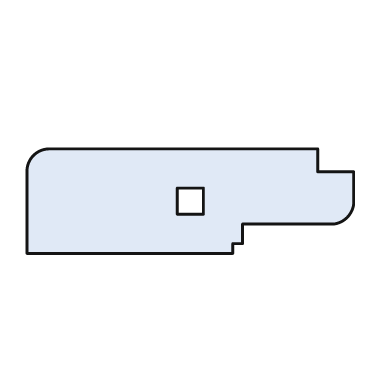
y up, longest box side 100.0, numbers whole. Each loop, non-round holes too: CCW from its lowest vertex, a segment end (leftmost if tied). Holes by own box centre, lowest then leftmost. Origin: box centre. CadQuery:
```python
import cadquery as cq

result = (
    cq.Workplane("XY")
    .moveTo(-50.0, -16.0)
    .lineTo(13.0, -16.0)
    .lineTo(13.0, -13.0)
    .lineTo(16.0, -13.0)
    .lineTo(16.0, -7.0)
    .lineTo(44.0, -7.0)
    .threePointArc((48.0, -5.0), (50.0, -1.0))
    .lineTo(50.0, 9.0)
    .lineTo(39.0, 9.0)
    .lineTo(39.0, 16.0)
    .lineTo(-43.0, 16.0)
    .threePointArc((-48.0, 14.0), (-50.0, 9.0))
    .close()
    .moveTo(-4.0, -4.0)
    .lineTo(4.0, -4.0)
    .lineTo(4.0, 4.0)
    .lineTo(-4.0, 4.0)
    .close()
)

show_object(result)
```